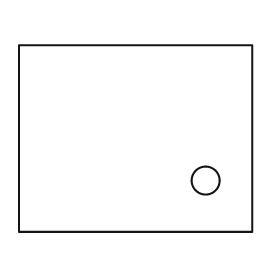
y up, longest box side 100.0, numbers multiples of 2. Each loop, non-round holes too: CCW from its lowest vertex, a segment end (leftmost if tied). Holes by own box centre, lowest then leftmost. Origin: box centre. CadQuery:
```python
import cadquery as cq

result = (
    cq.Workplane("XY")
    .moveTo(-50.0, -40.0)
    .lineTo(50.0, -40.0)
    .lineTo(50.0, 40.0)
    .lineTo(-50.0, 40.0)
    .close()
    .moveTo(30.0, -18.0)
    .circle(6.0)
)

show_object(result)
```